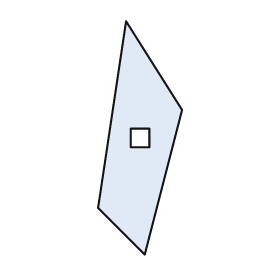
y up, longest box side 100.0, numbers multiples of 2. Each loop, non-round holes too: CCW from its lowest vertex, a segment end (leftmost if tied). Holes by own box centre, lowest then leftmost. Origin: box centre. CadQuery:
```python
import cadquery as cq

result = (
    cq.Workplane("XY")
    .moveTo(2.0, -50.0)
    .lineTo(18.0, 12.0)
    .lineTo(-6.0, 50.0)
    .lineTo(-18.0, -30.0)
    .close()
    .moveTo(-4.0, -4.0)
    .lineTo(4.0, -4.0)
    .lineTo(4.0, 4.0)
    .lineTo(-4.0, 4.0)
    .close()
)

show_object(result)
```